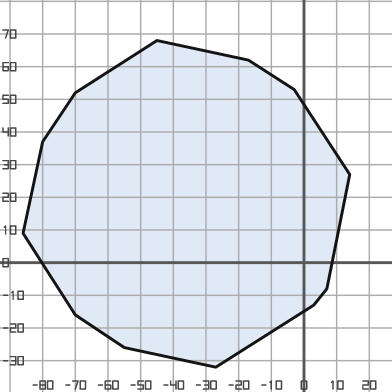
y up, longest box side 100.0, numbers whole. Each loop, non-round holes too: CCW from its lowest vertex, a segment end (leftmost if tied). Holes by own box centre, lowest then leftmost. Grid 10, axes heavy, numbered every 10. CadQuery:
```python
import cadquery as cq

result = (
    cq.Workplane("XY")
    .moveTo(-27.0, -32.0)
    .lineTo(3.0, -13.0)
    .lineTo(7.0, -8.0)
    .lineTo(14.0, 27.0)
    .lineTo(-3.0, 53.0)
    .lineTo(-17.0, 62.0)
    .lineTo(-45.0, 68.0)
    .lineTo(-70.0, 52.0)
    .lineTo(-80.0, 37.0)
    .lineTo(-86.0, 9.0)
    .lineTo(-70.0, -16.0)
    .lineTo(-55.0, -26.0)
    .close()
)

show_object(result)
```